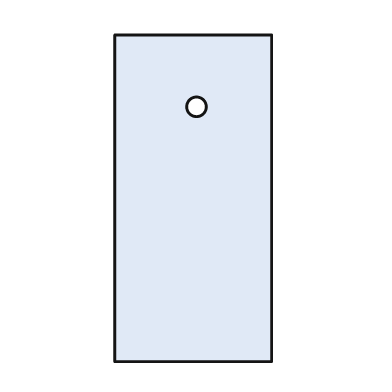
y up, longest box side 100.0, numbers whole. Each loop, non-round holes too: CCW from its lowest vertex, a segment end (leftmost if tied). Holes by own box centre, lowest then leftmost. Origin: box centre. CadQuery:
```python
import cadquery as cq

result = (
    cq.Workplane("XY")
    .moveTo(-24.0, -50.0)
    .lineTo(24.0, -50.0)
    .lineTo(24.0, 50.0)
    .lineTo(-24.0, 50.0)
    .close()
    .moveTo(1.0, 28.0)
    .circle(3.0)
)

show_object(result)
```